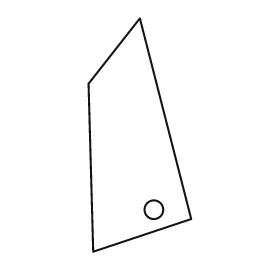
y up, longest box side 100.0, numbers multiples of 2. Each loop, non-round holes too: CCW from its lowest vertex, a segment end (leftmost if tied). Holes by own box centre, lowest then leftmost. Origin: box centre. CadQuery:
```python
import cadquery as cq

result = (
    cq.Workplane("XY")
    .moveTo(-20.0, -50.0)
    .lineTo(22.0, -36.0)
    .lineTo(0.0, 50.0)
    .lineTo(-22.0, 22.0)
    .close()
    .moveTo(6.0, -32.0)
    .circle(4.0)
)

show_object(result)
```